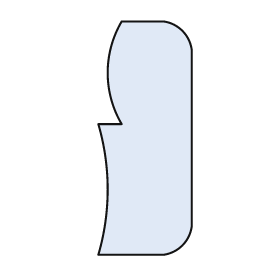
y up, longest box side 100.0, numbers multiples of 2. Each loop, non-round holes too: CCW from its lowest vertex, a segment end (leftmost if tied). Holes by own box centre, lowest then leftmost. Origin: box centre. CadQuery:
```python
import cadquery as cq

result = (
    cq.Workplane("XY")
    .moveTo(-20.0, -50.0)
    .lineTo(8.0, -50.0)
    .threePointArc((16.0, -46.0), (20.0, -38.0))
    .lineTo(20.0, 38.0)
    .threePointArc((16.0, 46.0), (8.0, 50.0))
    .lineTo(-10.0, 50.0)
    .threePointArc((-16.0, 28.0), (-10.0, 6.0))
    .lineTo(-20.0, 6.0)
    .threePointArc((-16.0, -22.0), (-20.0, -50.0))
    .close()
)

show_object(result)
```